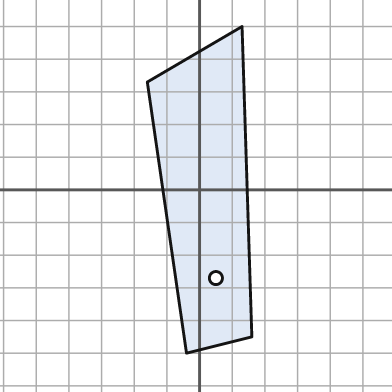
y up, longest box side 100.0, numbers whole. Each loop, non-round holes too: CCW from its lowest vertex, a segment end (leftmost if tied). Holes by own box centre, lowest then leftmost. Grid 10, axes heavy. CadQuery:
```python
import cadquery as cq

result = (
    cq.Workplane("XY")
    .moveTo(-4.0, -50.0)
    .lineTo(16.0, -45.0)
    .lineTo(13.0, 50.0)
    .lineTo(-16.0, 33.0)
    .close()
    .moveTo(5.0, -27.0)
    .circle(2.0)
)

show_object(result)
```